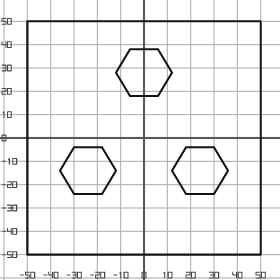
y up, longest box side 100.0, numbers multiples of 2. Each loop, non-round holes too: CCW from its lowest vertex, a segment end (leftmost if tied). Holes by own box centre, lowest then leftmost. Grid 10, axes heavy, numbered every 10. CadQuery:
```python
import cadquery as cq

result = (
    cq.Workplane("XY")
    .moveTo(-50.0, -50.0)
    .lineTo(50.0, -50.0)
    .lineTo(50.0, 50.0)
    .lineTo(-50.0, 50.0)
    .close()
    .moveTo(-30.0, -24.0)
    .lineTo(-18.0, -24.0)
    .lineTo(-12.0, -14.0)
    .lineTo(-18.0, -4.0)
    .lineTo(-30.0, -4.0)
    .lineTo(-36.0, -14.0)
    .close()
    .moveTo(18.0, -24.0)
    .lineTo(30.0, -24.0)
    .lineTo(36.0, -14.0)
    .lineTo(30.0, -4.0)
    .lineTo(18.0, -4.0)
    .lineTo(12.0, -14.0)
    .close()
    .moveTo(-6.0, 18.0)
    .lineTo(6.0, 18.0)
    .lineTo(12.0, 28.0)
    .lineTo(6.0, 38.0)
    .lineTo(-6.0, 38.0)
    .lineTo(-12.0, 28.0)
    .close()
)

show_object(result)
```